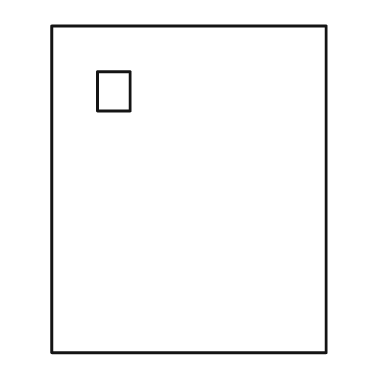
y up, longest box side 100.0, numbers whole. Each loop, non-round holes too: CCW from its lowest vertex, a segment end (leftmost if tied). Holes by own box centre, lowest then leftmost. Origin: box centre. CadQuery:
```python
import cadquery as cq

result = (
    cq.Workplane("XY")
    .moveTo(-42.0, -50.0)
    .lineTo(42.0, -50.0)
    .lineTo(42.0, 50.0)
    .lineTo(-42.0, 50.0)
    .close()
    .moveTo(-28.0, 24.0)
    .lineTo(-18.0, 24.0)
    .lineTo(-18.0, 36.0)
    .lineTo(-28.0, 36.0)
    .close()
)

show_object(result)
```